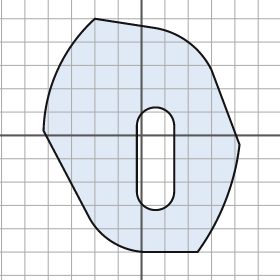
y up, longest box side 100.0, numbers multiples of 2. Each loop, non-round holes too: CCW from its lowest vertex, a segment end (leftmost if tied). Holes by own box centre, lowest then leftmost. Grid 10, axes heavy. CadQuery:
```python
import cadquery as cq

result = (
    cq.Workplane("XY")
    .moveTo(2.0, -50.0)
    .lineTo(24.0, -50.0)
    .threePointArc((36.0, -28.0), (42.0, -4.0))
    .lineTo(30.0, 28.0)
    .threePointArc((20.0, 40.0), (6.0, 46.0))
    .lineTo(-20.0, 50.0)
    .threePointArc((-36.0, 28.0), (-42.0, 2.0))
    .lineTo(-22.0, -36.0)
    .threePointArc((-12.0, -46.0), (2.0, -50.0))
    .close()
    .moveTo(-2.0, -24.0)
    .threePointArc((6.0, -32.0), (14.0, -24.0))
    .lineTo(14.0, 4.0)
    .threePointArc((6.0, 12.0), (-2.0, 4.0))
    .close()
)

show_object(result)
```